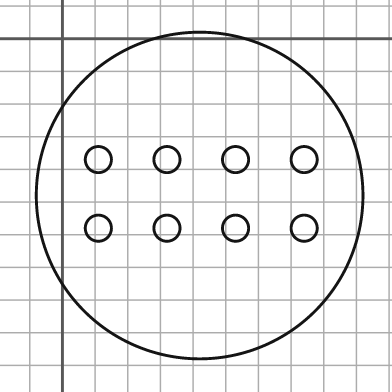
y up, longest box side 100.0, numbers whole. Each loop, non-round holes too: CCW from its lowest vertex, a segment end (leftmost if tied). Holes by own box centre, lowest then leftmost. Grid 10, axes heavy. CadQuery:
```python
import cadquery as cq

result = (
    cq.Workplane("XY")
    .moveTo(42.0, -48.0)
    .circle(50.0)
    .moveTo(11.0, -58.0)
    .circle(4.0)
    .moveTo(32.0, -58.0)
    .circle(4.0)
    .moveTo(53.0, -58.0)
    .circle(4.0)
    .moveTo(74.0, -58.0)
    .circle(4.0)
    .moveTo(11.0, -37.0)
    .circle(4.0)
    .moveTo(32.0, -37.0)
    .circle(4.0)
    .moveTo(53.0, -37.0)
    .circle(4.0)
    .moveTo(74.0, -37.0)
    .circle(4.0)
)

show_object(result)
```